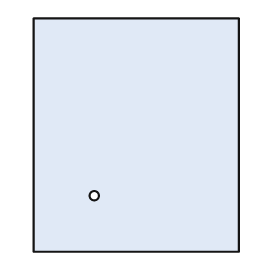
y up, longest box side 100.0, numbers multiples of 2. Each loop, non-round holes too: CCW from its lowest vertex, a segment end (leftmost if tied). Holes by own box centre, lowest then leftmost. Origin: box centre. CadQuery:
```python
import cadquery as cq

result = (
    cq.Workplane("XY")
    .moveTo(-44.0, -50.0)
    .lineTo(44.0, -50.0)
    .lineTo(44.0, 50.0)
    .lineTo(-44.0, 50.0)
    .close()
    .moveTo(-18.0, -26.0)
    .circle(2.0)
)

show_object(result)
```